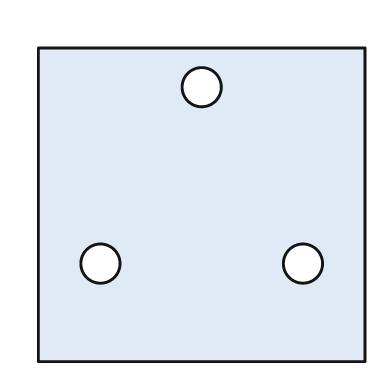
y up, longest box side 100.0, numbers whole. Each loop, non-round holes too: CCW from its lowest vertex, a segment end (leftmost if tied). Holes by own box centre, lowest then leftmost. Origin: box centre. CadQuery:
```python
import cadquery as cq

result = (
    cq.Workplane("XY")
    .moveTo(-50.0, -48.0)
    .lineTo(50.0, -48.0)
    .lineTo(50.0, 48.0)
    .lineTo(-50.0, 48.0)
    .close()
    .moveTo(-31.0, -18.0)
    .circle(6.0)
    .moveTo(31.0, -18.0)
    .circle(6.0)
    .moveTo(0.0, 36.0)
    .circle(6.0)
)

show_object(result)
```